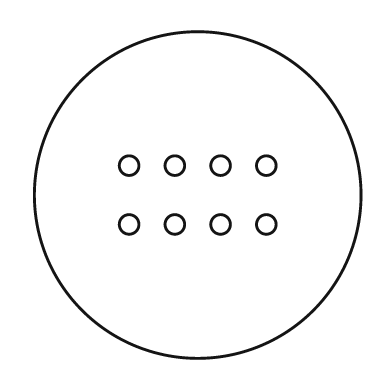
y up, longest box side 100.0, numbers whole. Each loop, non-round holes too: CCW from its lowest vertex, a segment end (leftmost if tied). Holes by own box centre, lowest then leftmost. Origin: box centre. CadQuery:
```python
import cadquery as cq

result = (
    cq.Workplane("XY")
    .moveTo(0.0, 0.0)
    .circle(50.0)
    .moveTo(-21.0, -9.0)
    .circle(3.0)
    .moveTo(-7.0, -9.0)
    .circle(3.0)
    .moveTo(7.0, -9.0)
    .circle(3.0)
    .moveTo(21.0, -9.0)
    .circle(3.0)
    .moveTo(-21.0, 9.0)
    .circle(3.0)
    .moveTo(-7.0, 9.0)
    .circle(3.0)
    .moveTo(7.0, 9.0)
    .circle(3.0)
    .moveTo(21.0, 9.0)
    .circle(3.0)
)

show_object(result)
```